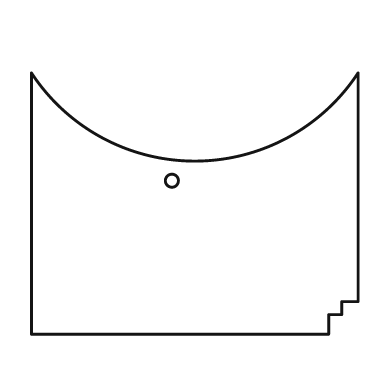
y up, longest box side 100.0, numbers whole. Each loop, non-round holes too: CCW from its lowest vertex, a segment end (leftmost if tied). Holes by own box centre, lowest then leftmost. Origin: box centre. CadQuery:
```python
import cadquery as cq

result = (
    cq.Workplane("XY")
    .moveTo(-50.0, -40.0)
    .lineTo(41.0, -40.0)
    .lineTo(41.0, -34.0)
    .lineTo(45.0, -34.0)
    .lineTo(45.0, -30.0)
    .lineTo(50.0, -30.0)
    .lineTo(50.0, 40.0)
    .threePointArc((0.0, 13.0), (-50.0, 40.0))
    .close()
    .moveTo(-7.0, 7.0)
    .circle(2.0)
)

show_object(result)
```